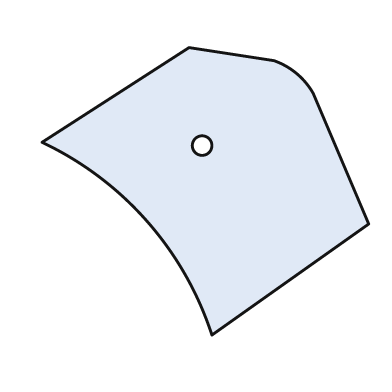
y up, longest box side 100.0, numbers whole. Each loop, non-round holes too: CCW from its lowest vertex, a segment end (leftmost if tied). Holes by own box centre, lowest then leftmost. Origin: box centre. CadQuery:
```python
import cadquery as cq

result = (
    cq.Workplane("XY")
    .moveTo(2.0, -44.0)
    .lineTo(50.0, -10.0)
    .lineTo(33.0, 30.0)
    .threePointArc((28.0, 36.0), (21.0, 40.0))
    .lineTo(-5.0, 44.0)
    .lineTo(-50.0, 15.0)
    .threePointArc((-18.0, -9.0), (2.0, -44.0))
    .close()
    .moveTo(-1.0, 14.0)
    .circle(3.0)
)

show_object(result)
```